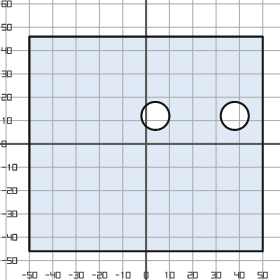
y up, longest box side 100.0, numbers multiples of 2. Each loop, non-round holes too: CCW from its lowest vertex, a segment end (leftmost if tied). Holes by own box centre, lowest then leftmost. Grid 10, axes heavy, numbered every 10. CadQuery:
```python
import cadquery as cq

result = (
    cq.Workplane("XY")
    .moveTo(-50.0, -46.0)
    .lineTo(50.0, -46.0)
    .lineTo(50.0, 46.0)
    .lineTo(-50.0, 46.0)
    .close()
    .moveTo(4.0, 12.0)
    .circle(6.0)
    .moveTo(38.0, 12.0)
    .circle(6.0)
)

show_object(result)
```